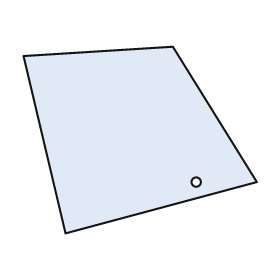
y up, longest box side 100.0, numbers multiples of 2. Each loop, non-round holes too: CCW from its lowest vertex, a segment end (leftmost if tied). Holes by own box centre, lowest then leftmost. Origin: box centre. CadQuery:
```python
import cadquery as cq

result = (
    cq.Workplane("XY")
    .moveTo(-32.0, -40.0)
    .lineTo(50.0, -18.0)
    .lineTo(14.0, 40.0)
    .lineTo(-50.0, 36.0)
    .close()
    .moveTo(24.0, -18.0)
    .circle(2.0)
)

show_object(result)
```